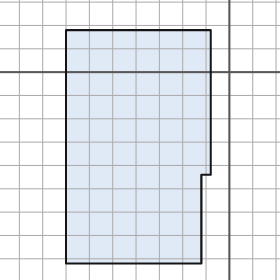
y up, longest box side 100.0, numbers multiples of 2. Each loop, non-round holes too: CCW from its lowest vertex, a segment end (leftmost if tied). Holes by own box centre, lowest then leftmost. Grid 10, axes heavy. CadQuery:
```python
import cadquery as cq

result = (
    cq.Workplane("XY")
    .moveTo(-70.0, -82.0)
    .lineTo(-12.0, -82.0)
    .lineTo(-12.0, -44.0)
    .lineTo(-8.0, -44.0)
    .lineTo(-8.0, 18.0)
    .lineTo(-70.0, 18.0)
    .close()
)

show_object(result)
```